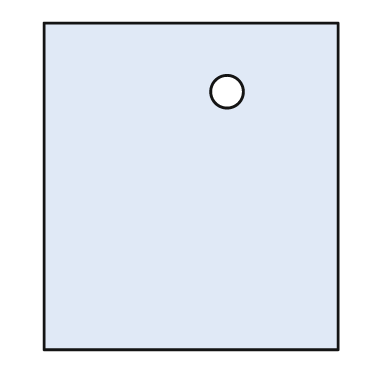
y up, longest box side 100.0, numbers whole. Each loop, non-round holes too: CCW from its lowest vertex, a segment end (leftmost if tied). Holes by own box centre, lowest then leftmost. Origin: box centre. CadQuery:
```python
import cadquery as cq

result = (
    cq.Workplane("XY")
    .moveTo(-45.0, -50.0)
    .lineTo(45.0, -50.0)
    .lineTo(45.0, 50.0)
    .lineTo(-45.0, 50.0)
    .close()
    .moveTo(11.0, 29.0)
    .circle(5.0)
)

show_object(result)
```